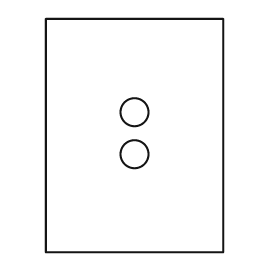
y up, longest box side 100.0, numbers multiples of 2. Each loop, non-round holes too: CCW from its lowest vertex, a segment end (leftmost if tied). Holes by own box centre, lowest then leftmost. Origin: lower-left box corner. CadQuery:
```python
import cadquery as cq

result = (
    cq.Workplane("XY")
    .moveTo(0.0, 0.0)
    .lineTo(76.0, 0.0)
    .lineTo(76.0, 100.0)
    .lineTo(0.0, 100.0)
    .close()
    .moveTo(38.0, 42.0)
    .circle(6.0)
    .moveTo(38.0, 60.0)
    .circle(6.0)
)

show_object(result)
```